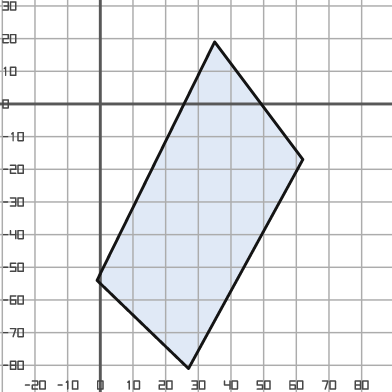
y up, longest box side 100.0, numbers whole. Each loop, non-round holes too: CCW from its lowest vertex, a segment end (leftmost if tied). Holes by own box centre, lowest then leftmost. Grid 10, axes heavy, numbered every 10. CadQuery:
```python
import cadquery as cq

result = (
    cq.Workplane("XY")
    .moveTo(27.0, -81.0)
    .lineTo(62.0, -17.0)
    .lineTo(35.0, 19.0)
    .lineTo(-1.0, -54.0)
    .close()
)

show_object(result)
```